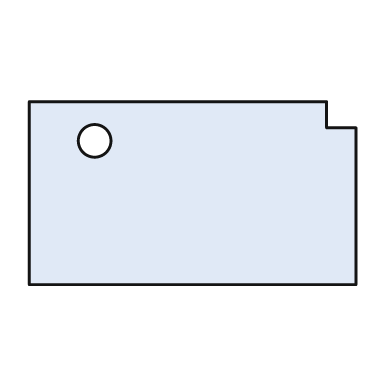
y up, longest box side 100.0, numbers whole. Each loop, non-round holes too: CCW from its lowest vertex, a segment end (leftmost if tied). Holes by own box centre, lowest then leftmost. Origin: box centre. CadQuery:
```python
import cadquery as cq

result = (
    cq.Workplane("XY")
    .moveTo(-50.0, -28.0)
    .lineTo(50.0, -28.0)
    .lineTo(50.0, 20.0)
    .lineTo(41.0, 20.0)
    .lineTo(41.0, 28.0)
    .lineTo(-50.0, 28.0)
    .close()
    .moveTo(-30.0, 16.0)
    .circle(5.0)
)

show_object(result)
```